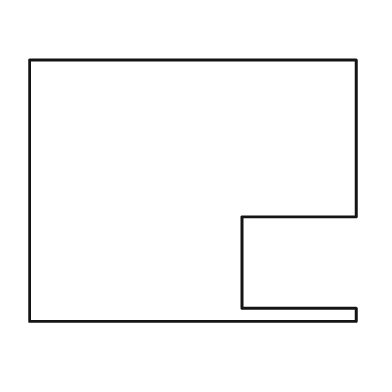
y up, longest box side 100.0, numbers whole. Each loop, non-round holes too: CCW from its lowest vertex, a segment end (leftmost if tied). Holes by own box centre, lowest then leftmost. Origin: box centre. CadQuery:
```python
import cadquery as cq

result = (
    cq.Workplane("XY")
    .moveTo(-50.0, -40.0)
    .lineTo(50.0, -40.0)
    .lineTo(50.0, -36.0)
    .lineTo(15.0, -36.0)
    .lineTo(15.0, -8.0)
    .lineTo(50.0, -8.0)
    .lineTo(50.0, 40.0)
    .lineTo(-50.0, 40.0)
    .close()
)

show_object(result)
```